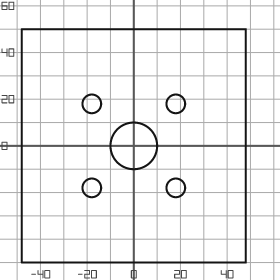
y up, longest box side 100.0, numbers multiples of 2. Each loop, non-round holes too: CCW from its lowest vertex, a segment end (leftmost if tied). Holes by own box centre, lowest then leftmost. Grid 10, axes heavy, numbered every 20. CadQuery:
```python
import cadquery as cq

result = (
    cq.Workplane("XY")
    .moveTo(-48.0, -50.0)
    .lineTo(48.0, -50.0)
    .lineTo(48.0, 50.0)
    .lineTo(-48.0, 50.0)
    .close()
    .moveTo(-18.0, -18.0)
    .circle(4.0)
    .moveTo(18.0, -18.0)
    .circle(4.0)
    .moveTo(0.0, 0.0)
    .circle(10.0)
    .moveTo(-18.0, 18.0)
    .circle(4.0)
    .moveTo(18.0, 18.0)
    .circle(4.0)
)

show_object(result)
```